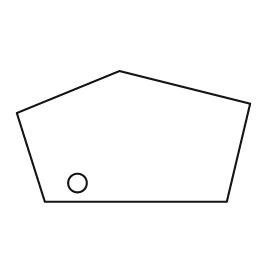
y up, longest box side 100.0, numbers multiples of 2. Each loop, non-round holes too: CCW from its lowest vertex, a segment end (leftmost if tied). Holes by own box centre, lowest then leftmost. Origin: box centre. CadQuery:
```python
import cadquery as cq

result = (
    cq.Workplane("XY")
    .moveTo(-38.0, -28.0)
    .lineTo(40.0, -28.0)
    .lineTo(50.0, 14.0)
    .lineTo(-6.0, 28.0)
    .lineTo(-50.0, 10.0)
    .close()
    .moveTo(-24.0, -20.0)
    .circle(4.0)
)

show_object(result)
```